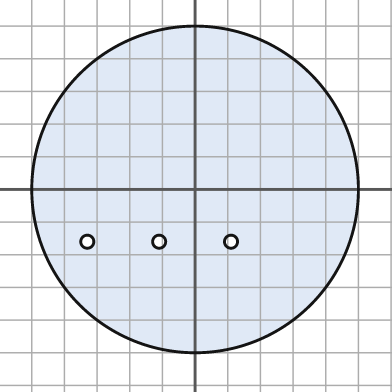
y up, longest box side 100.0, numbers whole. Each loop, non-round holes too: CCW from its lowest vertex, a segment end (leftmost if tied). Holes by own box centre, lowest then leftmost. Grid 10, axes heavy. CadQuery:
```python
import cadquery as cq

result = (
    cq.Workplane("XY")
    .moveTo(0.0, 0.0)
    .circle(50.0)
    .moveTo(-33.0, -16.0)
    .circle(2.0)
    .moveTo(-11.0, -16.0)
    .circle(2.0)
    .moveTo(11.0, -16.0)
    .circle(2.0)
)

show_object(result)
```